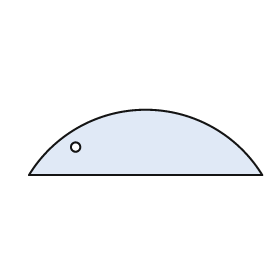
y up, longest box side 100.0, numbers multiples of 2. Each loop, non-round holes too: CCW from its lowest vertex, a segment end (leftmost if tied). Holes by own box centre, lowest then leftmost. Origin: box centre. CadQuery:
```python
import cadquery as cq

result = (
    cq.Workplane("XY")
    .moveTo(-50.0, -14.0)
    .lineTo(50.0, -14.0)
    .threePointArc((0.0, 14.0), (-50.0, -14.0))
    .close()
    .moveTo(-30.0, -2.0)
    .circle(2.0)
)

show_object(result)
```